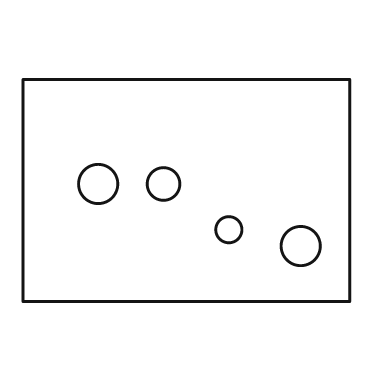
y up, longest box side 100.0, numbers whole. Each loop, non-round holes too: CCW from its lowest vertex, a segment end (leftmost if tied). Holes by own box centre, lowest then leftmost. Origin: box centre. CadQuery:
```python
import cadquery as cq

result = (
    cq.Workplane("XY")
    .moveTo(-50.0, -34.0)
    .lineTo(50.0, -34.0)
    .lineTo(50.0, 34.0)
    .lineTo(-50.0, 34.0)
    .close()
    .moveTo(35.0, -17.0)
    .circle(6.0)
    .moveTo(13.0, -12.0)
    .circle(4.0)
    .moveTo(-27.0, 2.0)
    .circle(6.0)
    .moveTo(-7.0, 2.0)
    .circle(5.0)
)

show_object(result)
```